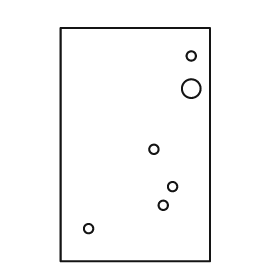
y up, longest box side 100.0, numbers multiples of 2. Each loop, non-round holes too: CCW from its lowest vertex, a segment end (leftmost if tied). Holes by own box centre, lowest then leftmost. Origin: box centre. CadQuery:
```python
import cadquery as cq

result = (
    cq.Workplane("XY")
    .moveTo(-32.0, -50.0)
    .lineTo(32.0, -50.0)
    .lineTo(32.0, 50.0)
    .lineTo(-32.0, 50.0)
    .close()
    .moveTo(-20.0, -36.0)
    .circle(2.0)
    .moveTo(12.0, -26.0)
    .circle(2.0)
    .moveTo(16.0, -18.0)
    .circle(2.0)
    .moveTo(8.0, -2.0)
    .circle(2.0)
    .moveTo(24.0, 24.0)
    .circle(4.0)
    .moveTo(24.0, 38.0)
    .circle(2.0)
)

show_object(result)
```